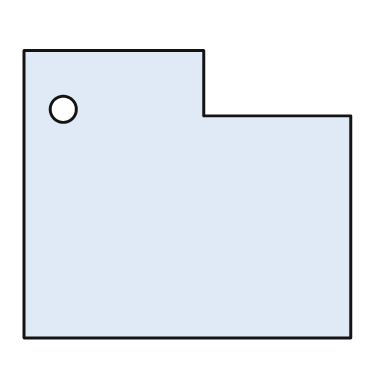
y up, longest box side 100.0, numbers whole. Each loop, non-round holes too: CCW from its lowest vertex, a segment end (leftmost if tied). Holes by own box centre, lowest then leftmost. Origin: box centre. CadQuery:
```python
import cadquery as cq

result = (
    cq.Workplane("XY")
    .moveTo(-50.0, -44.0)
    .lineTo(50.0, -44.0)
    .lineTo(50.0, 24.0)
    .lineTo(5.0, 24.0)
    .lineTo(5.0, 44.0)
    .lineTo(-50.0, 44.0)
    .close()
    .moveTo(-38.0, 26.0)
    .circle(4.0)
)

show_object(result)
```